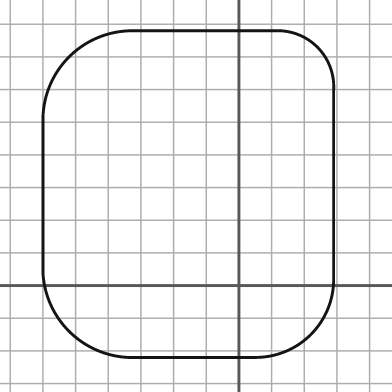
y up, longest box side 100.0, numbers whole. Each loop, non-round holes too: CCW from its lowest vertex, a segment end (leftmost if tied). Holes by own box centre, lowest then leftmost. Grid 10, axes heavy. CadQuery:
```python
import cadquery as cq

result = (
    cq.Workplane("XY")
    .moveTo(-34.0, -22.0)
    .lineTo(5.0, -22.0)
    .threePointArc((22.0, -15.0), (29.0, 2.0))
    .lineTo(29.0, 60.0)
    .threePointArc((24.0, 73.0), (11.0, 78.0))
    .lineTo(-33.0, 78.0)
    .threePointArc((-52.0, 70.0), (-60.0, 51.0))
    .lineTo(-60.0, 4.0)
    .threePointArc((-52.0, -14.0), (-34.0, -22.0))
    .close()
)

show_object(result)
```